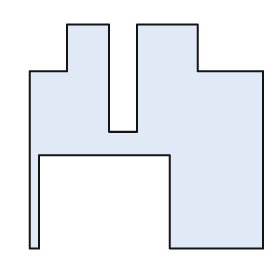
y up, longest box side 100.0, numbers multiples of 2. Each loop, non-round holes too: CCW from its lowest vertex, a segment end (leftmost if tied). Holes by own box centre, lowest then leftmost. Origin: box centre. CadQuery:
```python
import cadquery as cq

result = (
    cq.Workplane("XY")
    .moveTo(-50.0, -48.0)
    .lineTo(-46.0, -48.0)
    .lineTo(-46.0, -8.0)
    .lineTo(10.0, -8.0)
    .lineTo(10.0, -48.0)
    .lineTo(50.0, -48.0)
    .lineTo(50.0, 28.0)
    .lineTo(22.0, 28.0)
    .lineTo(22.0, 48.0)
    .lineTo(-4.0, 48.0)
    .lineTo(-4.0, 2.0)
    .lineTo(-16.0, 2.0)
    .lineTo(-16.0, 48.0)
    .lineTo(-34.0, 48.0)
    .lineTo(-34.0, 28.0)
    .lineTo(-50.0, 28.0)
    .close()
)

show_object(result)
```